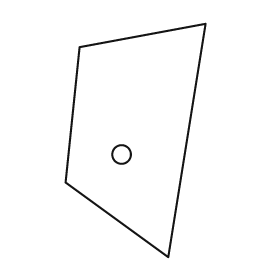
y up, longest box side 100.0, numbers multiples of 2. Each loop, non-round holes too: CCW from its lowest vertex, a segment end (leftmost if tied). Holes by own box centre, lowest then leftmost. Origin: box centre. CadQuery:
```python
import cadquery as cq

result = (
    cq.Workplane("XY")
    .moveTo(14.0, -50.0)
    .lineTo(30.0, 50.0)
    .lineTo(-24.0, 40.0)
    .lineTo(-30.0, -18.0)
    .close()
    .moveTo(-6.0, -6.0)
    .circle(4.0)
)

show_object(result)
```